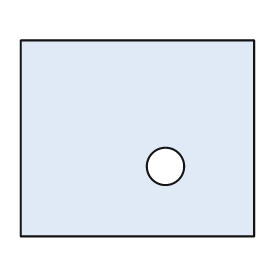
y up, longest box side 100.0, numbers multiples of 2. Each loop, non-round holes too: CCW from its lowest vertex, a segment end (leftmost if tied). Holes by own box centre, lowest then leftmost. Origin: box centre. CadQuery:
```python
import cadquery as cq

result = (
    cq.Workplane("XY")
    .moveTo(-50.0, -42.0)
    .lineTo(50.0, -42.0)
    .lineTo(50.0, 42.0)
    .lineTo(-50.0, 42.0)
    .close()
    .moveTo(12.0, -12.0)
    .circle(8.0)
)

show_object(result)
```